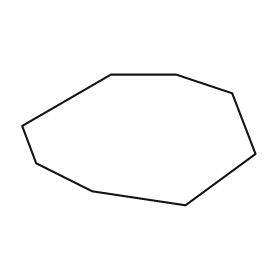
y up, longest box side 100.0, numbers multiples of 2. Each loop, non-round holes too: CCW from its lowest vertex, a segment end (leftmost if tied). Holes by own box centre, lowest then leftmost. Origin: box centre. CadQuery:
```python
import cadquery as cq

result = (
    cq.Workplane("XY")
    .moveTo(20.0, -28.0)
    .lineTo(50.0, -6.0)
    .lineTo(40.0, 20.0)
    .lineTo(16.0, 28.0)
    .lineTo(-12.0, 28.0)
    .lineTo(-50.0, 6.0)
    .lineTo(-44.0, -10.0)
    .lineTo(-20.0, -22.0)
    .close()
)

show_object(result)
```